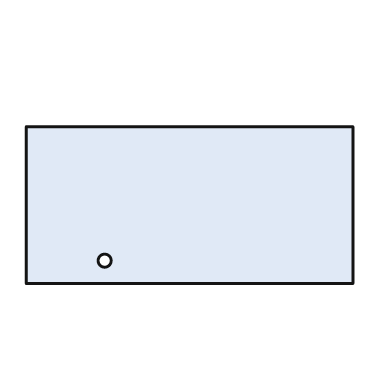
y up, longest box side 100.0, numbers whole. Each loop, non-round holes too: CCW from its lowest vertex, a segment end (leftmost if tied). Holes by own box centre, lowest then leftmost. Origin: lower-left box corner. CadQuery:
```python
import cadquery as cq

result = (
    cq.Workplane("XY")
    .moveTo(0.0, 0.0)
    .lineTo(100.0, 0.0)
    .lineTo(100.0, 48.0)
    .lineTo(0.0, 48.0)
    .close()
    .moveTo(24.0, 7.0)
    .circle(2.0)
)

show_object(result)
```